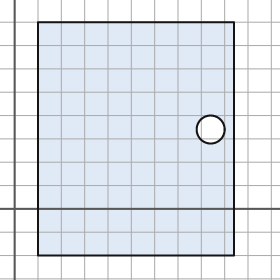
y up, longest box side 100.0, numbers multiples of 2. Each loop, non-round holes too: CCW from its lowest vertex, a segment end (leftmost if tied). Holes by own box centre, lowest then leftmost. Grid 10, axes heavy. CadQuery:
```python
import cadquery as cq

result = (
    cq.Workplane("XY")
    .moveTo(10.0, -20.0)
    .lineTo(94.0, -20.0)
    .lineTo(94.0, 80.0)
    .lineTo(10.0, 80.0)
    .close()
    .moveTo(84.0, 34.0)
    .circle(6.0)
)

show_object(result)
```